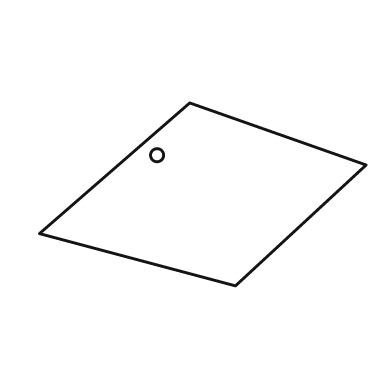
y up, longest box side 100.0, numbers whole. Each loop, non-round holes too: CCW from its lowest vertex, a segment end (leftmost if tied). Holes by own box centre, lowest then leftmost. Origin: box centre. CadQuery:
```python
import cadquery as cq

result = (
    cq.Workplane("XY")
    .moveTo(10.0, -28.0)
    .lineTo(50.0, 9.0)
    .lineTo(-4.0, 28.0)
    .lineTo(-50.0, -12.0)
    .close()
    .moveTo(-14.0, 12.0)
    .circle(2.0)
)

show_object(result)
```